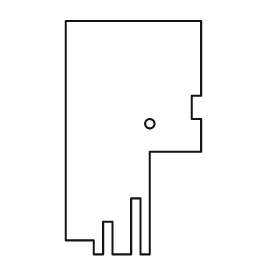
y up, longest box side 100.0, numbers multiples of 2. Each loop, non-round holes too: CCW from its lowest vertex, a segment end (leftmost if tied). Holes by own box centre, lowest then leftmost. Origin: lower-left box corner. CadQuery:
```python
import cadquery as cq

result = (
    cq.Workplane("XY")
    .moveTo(12.0, 0.0)
    .lineTo(16.0, 0.0)
    .lineTo(16.0, 14.0)
    .lineTo(20.0, 14.0)
    .lineTo(20.0, 0.0)
    .lineTo(28.0, 0.0)
    .lineTo(28.0, 24.0)
    .lineTo(32.0, 24.0)
    .lineTo(32.0, 0.0)
    .lineTo(36.0, 0.0)
    .lineTo(36.0, 44.0)
    .lineTo(58.0, 44.0)
    .lineTo(58.0, 58.0)
    .lineTo(54.0, 58.0)
    .lineTo(54.0, 68.0)
    .lineTo(58.0, 68.0)
    .lineTo(58.0, 100.0)
    .lineTo(0.0, 100.0)
    .lineTo(0.0, 6.0)
    .lineTo(12.0, 6.0)
    .close()
    .moveTo(36.0, 56.0)
    .circle(2.0)
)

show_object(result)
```